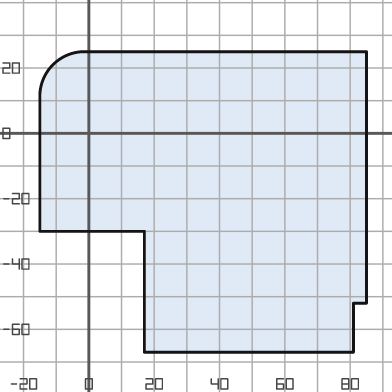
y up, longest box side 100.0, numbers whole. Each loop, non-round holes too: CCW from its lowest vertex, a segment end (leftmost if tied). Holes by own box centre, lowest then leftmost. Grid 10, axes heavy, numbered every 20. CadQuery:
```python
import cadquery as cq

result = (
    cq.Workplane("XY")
    .moveTo(17.0, -67.0)
    .lineTo(81.0, -67.0)
    .lineTo(81.0, -52.0)
    .lineTo(85.0, -52.0)
    .lineTo(85.0, 25.0)
    .lineTo(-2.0, 25.0)
    .threePointArc((-11.0, 21.0), (-15.0, 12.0))
    .lineTo(-15.0, -30.0)
    .lineTo(17.0, -30.0)
    .close()
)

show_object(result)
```